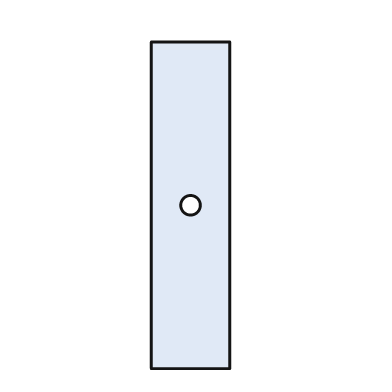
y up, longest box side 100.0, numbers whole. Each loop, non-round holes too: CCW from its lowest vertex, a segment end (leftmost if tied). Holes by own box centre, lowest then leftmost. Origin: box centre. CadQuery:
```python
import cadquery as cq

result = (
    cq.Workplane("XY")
    .moveTo(-12.0, -50.0)
    .lineTo(12.0, -50.0)
    .lineTo(12.0, 50.0)
    .lineTo(-12.0, 50.0)
    .close()
    .moveTo(0.0, 0.0)
    .circle(3.0)
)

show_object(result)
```